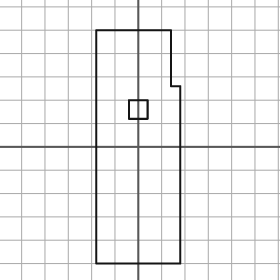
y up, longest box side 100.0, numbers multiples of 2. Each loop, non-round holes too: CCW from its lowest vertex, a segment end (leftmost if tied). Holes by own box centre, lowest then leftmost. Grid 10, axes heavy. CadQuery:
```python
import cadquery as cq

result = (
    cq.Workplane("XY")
    .moveTo(-18.0, -50.0)
    .lineTo(18.0, -50.0)
    .lineTo(18.0, 26.0)
    .lineTo(14.0, 26.0)
    .lineTo(14.0, 50.0)
    .lineTo(-18.0, 50.0)
    .close()
    .moveTo(-4.0, 12.0)
    .lineTo(4.0, 12.0)
    .lineTo(4.0, 20.0)
    .lineTo(-4.0, 20.0)
    .close()
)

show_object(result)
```